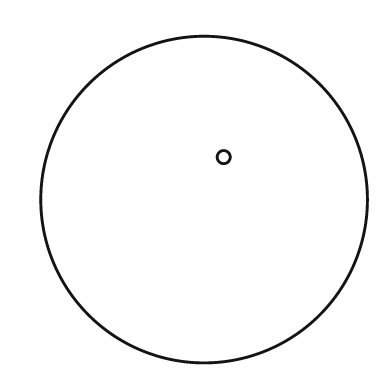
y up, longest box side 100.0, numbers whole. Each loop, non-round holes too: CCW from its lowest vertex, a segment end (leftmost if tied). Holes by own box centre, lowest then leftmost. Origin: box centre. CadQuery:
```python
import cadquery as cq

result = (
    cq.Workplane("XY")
    .moveTo(0.0, 0.0)
    .circle(50.0)
    .moveTo(6.0, 13.0)
    .circle(2.0)
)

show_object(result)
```